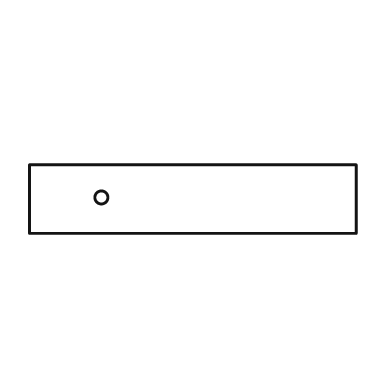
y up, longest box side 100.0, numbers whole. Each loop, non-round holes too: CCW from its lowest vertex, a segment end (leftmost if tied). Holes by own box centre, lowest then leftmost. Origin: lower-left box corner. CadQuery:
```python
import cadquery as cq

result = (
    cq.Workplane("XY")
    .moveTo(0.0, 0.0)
    .lineTo(100.0, 0.0)
    .lineTo(100.0, 21.0)
    .lineTo(0.0, 21.0)
    .close()
    .moveTo(22.0, 11.0)
    .circle(2.0)
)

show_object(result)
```